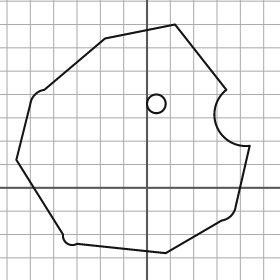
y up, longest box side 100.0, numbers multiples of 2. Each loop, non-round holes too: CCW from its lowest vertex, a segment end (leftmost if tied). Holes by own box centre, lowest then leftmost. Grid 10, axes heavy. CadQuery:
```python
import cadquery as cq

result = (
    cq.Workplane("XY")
    .moveTo(8.0, -28.0)
    .lineTo(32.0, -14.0)
    .threePointArc((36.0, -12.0), (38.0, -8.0))
    .lineTo(44.0, 18.0)
    .threePointArc((30.0, 26.0), (34.0, 42.0))
    .lineTo(12.0, 70.0)
    .lineTo(-18.0, 64.0)
    .lineTo(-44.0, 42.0)
    .threePointArc((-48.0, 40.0), (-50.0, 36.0))
    .lineTo(-56.0, 12.0)
    .lineTo(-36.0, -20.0)
    .threePointArc((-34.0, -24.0), (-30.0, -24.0))
    .close()
    .moveTo(4.0, 36.0)
    .circle(4.0)
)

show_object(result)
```